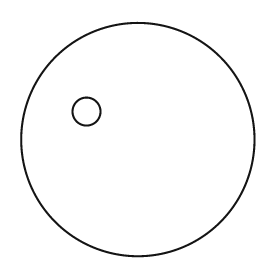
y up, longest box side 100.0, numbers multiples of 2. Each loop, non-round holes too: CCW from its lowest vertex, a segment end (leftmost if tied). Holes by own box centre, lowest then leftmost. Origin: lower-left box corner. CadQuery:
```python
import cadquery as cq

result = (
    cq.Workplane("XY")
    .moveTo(50.0, 50.0)
    .circle(50.0)
    .moveTo(28.0, 62.0)
    .circle(6.0)
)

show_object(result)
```